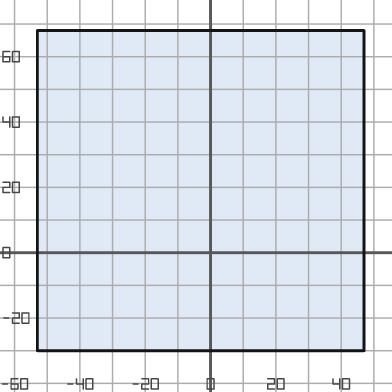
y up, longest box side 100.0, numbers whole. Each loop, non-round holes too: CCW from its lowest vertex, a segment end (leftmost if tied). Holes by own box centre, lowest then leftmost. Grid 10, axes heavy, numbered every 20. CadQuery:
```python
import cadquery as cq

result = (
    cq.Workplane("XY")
    .moveTo(-53.0, -30.0)
    .lineTo(47.0, -30.0)
    .lineTo(47.0, 68.0)
    .lineTo(-53.0, 68.0)
    .close()
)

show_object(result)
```